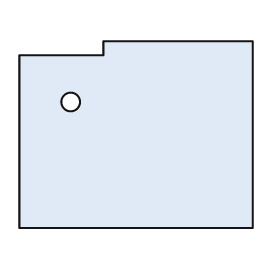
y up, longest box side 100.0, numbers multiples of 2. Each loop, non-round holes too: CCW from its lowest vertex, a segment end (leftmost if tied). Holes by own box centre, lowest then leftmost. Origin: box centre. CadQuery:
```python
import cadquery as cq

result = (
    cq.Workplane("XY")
    .moveTo(-50.0, -40.0)
    .lineTo(50.0, -40.0)
    .lineTo(50.0, 40.0)
    .lineTo(-14.0, 40.0)
    .lineTo(-14.0, 34.0)
    .lineTo(-50.0, 34.0)
    .close()
    .moveTo(-28.0, 14.0)
    .circle(4.0)
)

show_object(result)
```